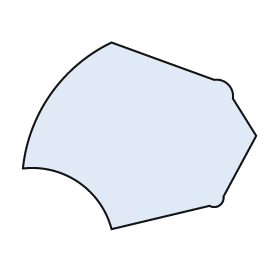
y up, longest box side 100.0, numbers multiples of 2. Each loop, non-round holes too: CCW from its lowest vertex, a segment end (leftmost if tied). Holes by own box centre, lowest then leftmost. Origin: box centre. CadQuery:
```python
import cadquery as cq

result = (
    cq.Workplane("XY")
    .moveTo(-12.0, -40.0)
    .lineTo(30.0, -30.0)
    .threePointArc((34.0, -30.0), (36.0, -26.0))
    .lineTo(50.0, 0.0)
    .lineTo(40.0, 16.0)
    .threePointArc((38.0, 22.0), (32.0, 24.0))
    .lineTo(-12.0, 40.0)
    .threePointArc((-38.0, 18.0), (-50.0, -14.0))
    .threePointArc((-26.0, -20.0), (-12.0, -40.0))
    .close()
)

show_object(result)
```